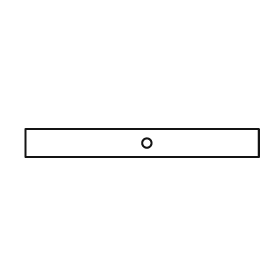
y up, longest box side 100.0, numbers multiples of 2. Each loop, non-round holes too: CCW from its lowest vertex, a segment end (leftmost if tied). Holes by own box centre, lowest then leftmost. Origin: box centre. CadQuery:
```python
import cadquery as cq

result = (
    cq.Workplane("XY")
    .moveTo(-50.0, -6.0)
    .lineTo(50.0, -6.0)
    .lineTo(50.0, 6.0)
    .lineTo(-50.0, 6.0)
    .close()
    .moveTo(2.0, 0.0)
    .circle(2.0)
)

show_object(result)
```